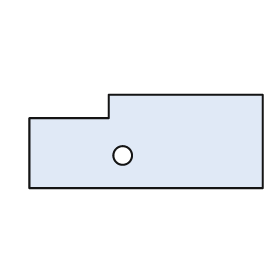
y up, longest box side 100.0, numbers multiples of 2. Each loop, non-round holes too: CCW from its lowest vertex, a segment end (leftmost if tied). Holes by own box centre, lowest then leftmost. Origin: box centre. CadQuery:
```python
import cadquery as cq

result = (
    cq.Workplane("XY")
    .moveTo(-50.0, -20.0)
    .lineTo(50.0, -20.0)
    .lineTo(50.0, 20.0)
    .lineTo(-16.0, 20.0)
    .lineTo(-16.0, 10.0)
    .lineTo(-50.0, 10.0)
    .close()
    .moveTo(-10.0, -6.0)
    .circle(4.0)
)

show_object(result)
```